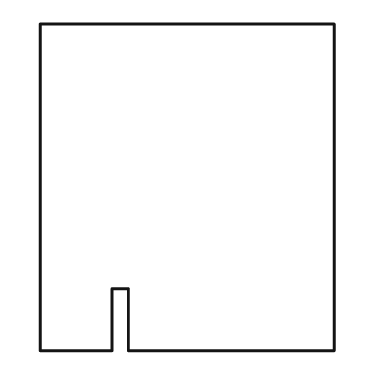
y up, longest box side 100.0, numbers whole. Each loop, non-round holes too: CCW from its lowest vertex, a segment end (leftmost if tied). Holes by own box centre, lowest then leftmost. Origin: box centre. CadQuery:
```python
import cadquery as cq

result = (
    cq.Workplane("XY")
    .moveTo(-45.0, -50.0)
    .lineTo(-23.0, -50.0)
    .lineTo(-23.0, -31.0)
    .lineTo(-18.0, -31.0)
    .lineTo(-18.0, -50.0)
    .lineTo(45.0, -50.0)
    .lineTo(45.0, 50.0)
    .lineTo(-45.0, 50.0)
    .close()
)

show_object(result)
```